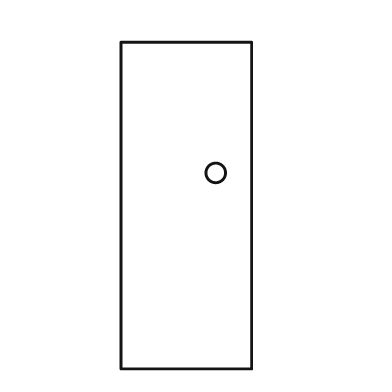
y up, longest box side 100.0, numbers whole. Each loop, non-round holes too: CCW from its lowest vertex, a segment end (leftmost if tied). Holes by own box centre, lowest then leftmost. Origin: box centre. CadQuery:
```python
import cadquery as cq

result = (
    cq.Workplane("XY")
    .moveTo(-20.0, -50.0)
    .lineTo(20.0, -50.0)
    .lineTo(20.0, 50.0)
    .lineTo(-20.0, 50.0)
    .close()
    .moveTo(9.0, 10.0)
    .circle(3.0)
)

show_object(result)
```